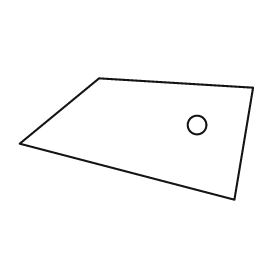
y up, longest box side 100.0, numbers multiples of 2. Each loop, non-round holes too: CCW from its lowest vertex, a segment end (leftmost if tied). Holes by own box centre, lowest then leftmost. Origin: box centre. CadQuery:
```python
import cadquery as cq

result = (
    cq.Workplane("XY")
    .moveTo(42.0, -26.0)
    .lineTo(50.0, 22.0)
    .lineTo(-16.0, 26.0)
    .lineTo(-50.0, -2.0)
    .close()
    .moveTo(26.0, 6.0)
    .circle(4.0)
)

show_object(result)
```